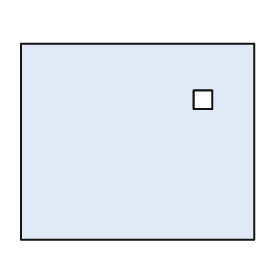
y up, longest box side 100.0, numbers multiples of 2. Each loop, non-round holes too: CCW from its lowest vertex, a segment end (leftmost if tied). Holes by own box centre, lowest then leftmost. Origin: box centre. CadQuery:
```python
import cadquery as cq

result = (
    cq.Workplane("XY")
    .moveTo(-50.0, -42.0)
    .lineTo(50.0, -42.0)
    .lineTo(50.0, 42.0)
    .lineTo(-50.0, 42.0)
    .close()
    .moveTo(24.0, 14.0)
    .lineTo(32.0, 14.0)
    .lineTo(32.0, 22.0)
    .lineTo(24.0, 22.0)
    .close()
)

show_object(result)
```